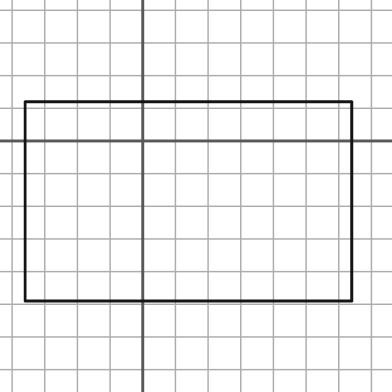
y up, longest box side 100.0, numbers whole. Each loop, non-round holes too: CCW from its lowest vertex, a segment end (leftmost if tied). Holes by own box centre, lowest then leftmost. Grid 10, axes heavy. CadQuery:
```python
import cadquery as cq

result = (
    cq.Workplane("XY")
    .moveTo(-36.0, -49.0)
    .lineTo(64.0, -49.0)
    .lineTo(64.0, 12.0)
    .lineTo(-36.0, 12.0)
    .close()
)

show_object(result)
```